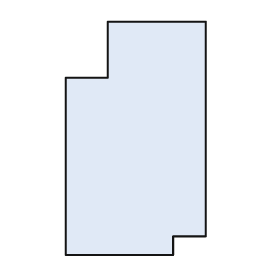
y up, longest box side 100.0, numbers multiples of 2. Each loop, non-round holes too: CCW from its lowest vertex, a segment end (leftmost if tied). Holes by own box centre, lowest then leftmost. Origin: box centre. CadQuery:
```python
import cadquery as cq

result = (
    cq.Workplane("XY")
    .moveTo(-30.0, -50.0)
    .lineTo(16.0, -50.0)
    .lineTo(16.0, -42.0)
    .lineTo(30.0, -42.0)
    .lineTo(30.0, 50.0)
    .lineTo(-12.0, 50.0)
    .lineTo(-12.0, 26.0)
    .lineTo(-30.0, 26.0)
    .close()
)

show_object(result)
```